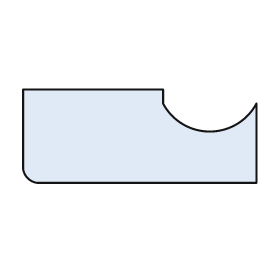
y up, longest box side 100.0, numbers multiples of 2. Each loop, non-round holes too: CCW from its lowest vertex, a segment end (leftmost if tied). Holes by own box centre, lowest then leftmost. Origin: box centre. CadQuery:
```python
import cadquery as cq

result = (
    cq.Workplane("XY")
    .moveTo(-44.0, -20.0)
    .lineTo(50.0, -20.0)
    .lineTo(50.0, 14.0)
    .threePointArc((30.0, 2.0), (10.0, 14.0))
    .lineTo(10.0, 20.0)
    .lineTo(-50.0, 20.0)
    .lineTo(-50.0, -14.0)
    .threePointArc((-48.0, -18.0), (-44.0, -20.0))
    .close()
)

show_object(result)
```